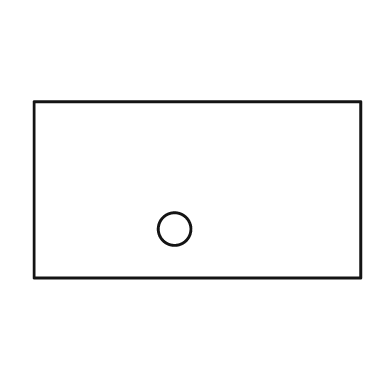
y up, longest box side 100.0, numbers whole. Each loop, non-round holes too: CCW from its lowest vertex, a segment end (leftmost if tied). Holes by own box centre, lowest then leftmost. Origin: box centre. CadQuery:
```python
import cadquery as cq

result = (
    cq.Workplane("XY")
    .moveTo(-50.0, -27.0)
    .lineTo(50.0, -27.0)
    .lineTo(50.0, 27.0)
    .lineTo(-50.0, 27.0)
    .close()
    .moveTo(-7.0, -12.0)
    .circle(5.0)
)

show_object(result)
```